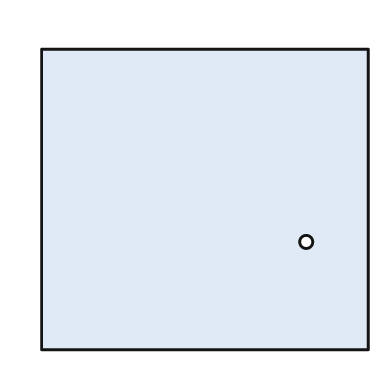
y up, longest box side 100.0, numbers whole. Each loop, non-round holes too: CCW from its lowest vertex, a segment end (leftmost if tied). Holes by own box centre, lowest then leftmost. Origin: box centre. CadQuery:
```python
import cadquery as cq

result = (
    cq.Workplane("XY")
    .moveTo(-50.0, -46.0)
    .lineTo(50.0, -46.0)
    .lineTo(50.0, 46.0)
    .lineTo(-50.0, 46.0)
    .close()
    .moveTo(31.0, -13.0)
    .circle(2.0)
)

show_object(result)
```